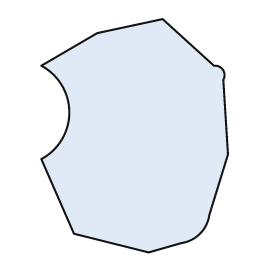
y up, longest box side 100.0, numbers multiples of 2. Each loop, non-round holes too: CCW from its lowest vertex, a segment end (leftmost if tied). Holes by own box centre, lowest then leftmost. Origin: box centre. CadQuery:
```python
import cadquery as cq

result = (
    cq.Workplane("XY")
    .moveTo(6.0, -50.0)
    .lineTo(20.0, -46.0)
    .threePointArc((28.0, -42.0), (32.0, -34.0))
    .lineTo(40.0, -8.0)
    .lineTo(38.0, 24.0)
    .threePointArc((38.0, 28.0), (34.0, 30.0))
    .lineTo(12.0, 50.0)
    .lineTo(-16.0, 44.0)
    .lineTo(-40.0, 30.0)
    .threePointArc((-28.0, 10.0), (-40.0, -10.0))
    .lineTo(-26.0, -42.0)
    .close()
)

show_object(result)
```